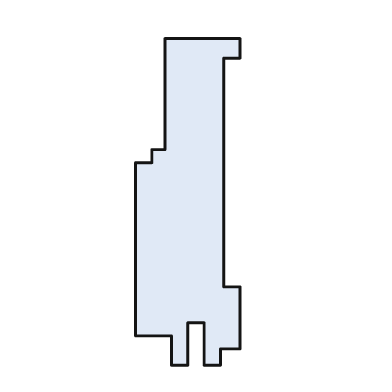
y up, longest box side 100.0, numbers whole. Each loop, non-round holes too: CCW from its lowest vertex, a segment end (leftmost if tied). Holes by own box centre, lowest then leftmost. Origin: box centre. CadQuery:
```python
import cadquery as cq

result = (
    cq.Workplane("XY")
    .moveTo(-5.0, -50.0)
    .lineTo(0.0, -50.0)
    .lineTo(0.0, -37.0)
    .lineTo(5.0, -37.0)
    .lineTo(5.0, -50.0)
    .lineTo(10.0, -50.0)
    .lineTo(10.0, -45.0)
    .lineTo(16.0, -45.0)
    .lineTo(16.0, -26.0)
    .lineTo(11.0, -26.0)
    .lineTo(11.0, 44.0)
    .lineTo(16.0, 44.0)
    .lineTo(16.0, 50.0)
    .lineTo(-7.0, 50.0)
    .lineTo(-7.0, 16.0)
    .lineTo(-11.0, 16.0)
    .lineTo(-11.0, 12.0)
    .lineTo(-16.0, 12.0)
    .lineTo(-16.0, -41.0)
    .lineTo(-5.0, -41.0)
    .close()
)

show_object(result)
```